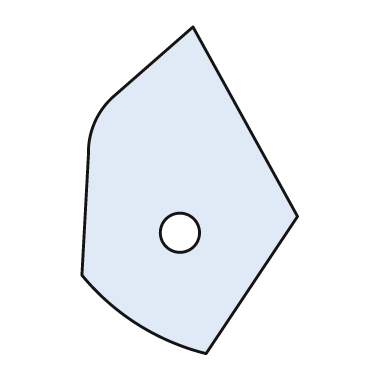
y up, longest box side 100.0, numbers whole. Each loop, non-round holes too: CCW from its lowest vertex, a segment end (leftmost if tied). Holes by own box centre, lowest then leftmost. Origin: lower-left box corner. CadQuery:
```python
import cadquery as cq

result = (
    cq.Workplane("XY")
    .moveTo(38.0, 0.0)
    .lineTo(66.0, 42.0)
    .lineTo(34.0, 100.0)
    .lineTo(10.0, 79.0)
    .threePointArc((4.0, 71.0), (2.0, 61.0))
    .lineTo(0.0, 24.0)
    .threePointArc((17.0, 9.0), (38.0, 0.0))
    .close()
    .moveTo(30.0, 37.0)
    .circle(6.0)
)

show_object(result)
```